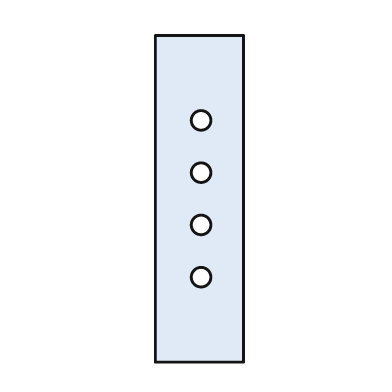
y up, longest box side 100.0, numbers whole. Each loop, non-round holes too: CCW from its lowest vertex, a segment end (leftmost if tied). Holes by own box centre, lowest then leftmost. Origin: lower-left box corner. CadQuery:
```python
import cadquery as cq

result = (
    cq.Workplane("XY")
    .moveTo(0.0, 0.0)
    .lineTo(27.0, 0.0)
    .lineTo(27.0, 100.0)
    .lineTo(0.0, 100.0)
    .close()
    .moveTo(14.0, 26.0)
    .circle(3.0)
    .moveTo(14.0, 42.0)
    .circle(3.0)
    .moveTo(14.0, 58.0)
    .circle(3.0)
    .moveTo(14.0, 74.0)
    .circle(3.0)
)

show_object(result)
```